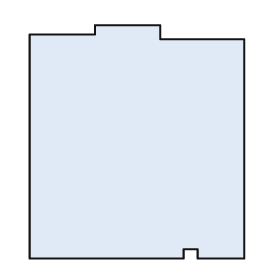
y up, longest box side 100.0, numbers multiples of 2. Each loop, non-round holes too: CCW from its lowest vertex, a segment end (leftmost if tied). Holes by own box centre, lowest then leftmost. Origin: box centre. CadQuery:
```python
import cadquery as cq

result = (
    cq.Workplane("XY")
    .moveTo(-46.0, -50.0)
    .lineTo(20.0, -50.0)
    .lineTo(20.0, -46.0)
    .lineTo(26.0, -46.0)
    .lineTo(26.0, -50.0)
    .lineTo(46.0, -50.0)
    .lineTo(46.0, 44.0)
    .lineTo(10.0, 44.0)
    .lineTo(10.0, 50.0)
    .lineTo(-18.0, 50.0)
    .lineTo(-18.0, 46.0)
    .lineTo(-46.0, 46.0)
    .close()
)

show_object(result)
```